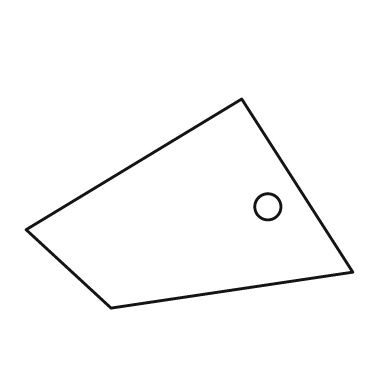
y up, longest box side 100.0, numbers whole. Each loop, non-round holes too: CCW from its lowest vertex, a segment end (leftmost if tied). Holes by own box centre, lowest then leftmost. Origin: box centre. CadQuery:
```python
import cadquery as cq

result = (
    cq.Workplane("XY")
    .moveTo(-24.0, -32.0)
    .lineTo(50.0, -21.0)
    .lineTo(16.0, 32.0)
    .lineTo(-50.0, -8.0)
    .close()
    .moveTo(24.0, -1.0)
    .circle(4.0)
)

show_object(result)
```